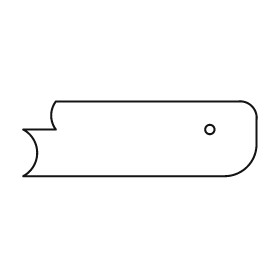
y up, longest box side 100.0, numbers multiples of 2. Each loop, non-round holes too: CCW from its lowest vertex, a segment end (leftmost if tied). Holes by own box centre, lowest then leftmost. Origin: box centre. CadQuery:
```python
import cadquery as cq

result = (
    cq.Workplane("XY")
    .moveTo(-50.0, -16.0)
    .lineTo(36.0, -16.0)
    .threePointArc((46.0, -12.0), (50.0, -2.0))
    .lineTo(50.0, 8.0)
    .threePointArc((48.0, 14.0), (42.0, 16.0))
    .lineTo(-36.0, 16.0)
    .threePointArc((-38.0, 10.0), (-36.0, 4.0))
    .lineTo(-50.0, 4.0)
    .threePointArc((-44.0, -6.0), (-50.0, -16.0))
    .close()
    .moveTo(30.0, 4.0)
    .circle(2.0)
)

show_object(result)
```